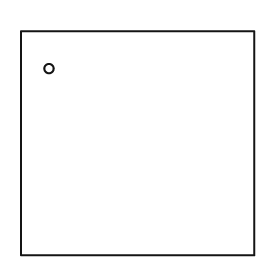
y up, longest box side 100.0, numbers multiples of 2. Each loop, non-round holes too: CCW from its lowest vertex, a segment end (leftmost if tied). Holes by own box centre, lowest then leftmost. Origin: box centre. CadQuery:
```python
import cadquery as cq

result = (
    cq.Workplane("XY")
    .moveTo(-50.0, -48.0)
    .lineTo(50.0, -48.0)
    .lineTo(50.0, 48.0)
    .lineTo(-50.0, 48.0)
    .close()
    .moveTo(-38.0, 32.0)
    .circle(2.0)
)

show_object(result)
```